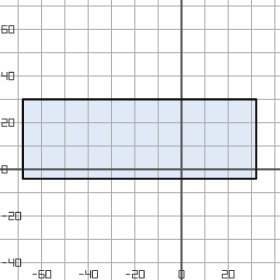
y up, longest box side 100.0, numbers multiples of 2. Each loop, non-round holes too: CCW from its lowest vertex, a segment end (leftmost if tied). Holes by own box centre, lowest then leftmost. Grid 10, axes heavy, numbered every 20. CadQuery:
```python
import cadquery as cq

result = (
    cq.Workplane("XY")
    .moveTo(-68.0, -4.0)
    .lineTo(32.0, -4.0)
    .lineTo(32.0, 30.0)
    .lineTo(-68.0, 30.0)
    .close()
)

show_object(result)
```